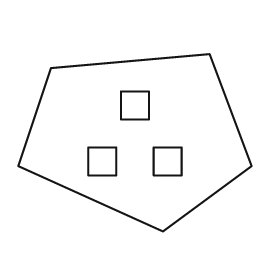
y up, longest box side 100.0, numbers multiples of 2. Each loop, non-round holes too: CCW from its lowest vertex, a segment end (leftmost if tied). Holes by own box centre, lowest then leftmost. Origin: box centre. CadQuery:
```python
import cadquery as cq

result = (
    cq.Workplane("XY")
    .moveTo(12.0, -38.0)
    .lineTo(50.0, -10.0)
    .lineTo(32.0, 38.0)
    .lineTo(-36.0, 32.0)
    .lineTo(-50.0, -10.0)
    .close()
    .moveTo(-20.0, -14.0)
    .lineTo(-8.0, -14.0)
    .lineTo(-8.0, -2.0)
    .lineTo(-20.0, -2.0)
    .close()
    .moveTo(8.0, -14.0)
    .lineTo(20.0, -14.0)
    .lineTo(20.0, -2.0)
    .lineTo(8.0, -2.0)
    .close()
    .moveTo(-6.0, 10.0)
    .lineTo(6.0, 10.0)
    .lineTo(6.0, 22.0)
    .lineTo(-6.0, 22.0)
    .close()
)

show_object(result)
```